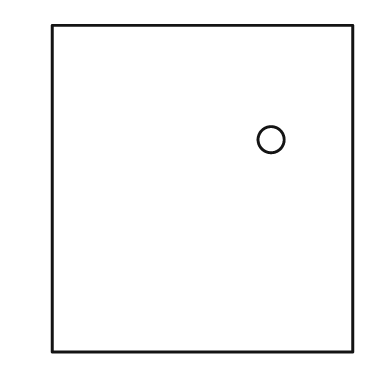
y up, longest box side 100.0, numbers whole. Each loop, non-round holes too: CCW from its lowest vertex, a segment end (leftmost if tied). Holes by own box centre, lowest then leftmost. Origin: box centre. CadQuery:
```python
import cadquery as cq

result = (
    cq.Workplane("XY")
    .moveTo(-46.0, -50.0)
    .lineTo(46.0, -50.0)
    .lineTo(46.0, 50.0)
    .lineTo(-46.0, 50.0)
    .close()
    .moveTo(21.0, 15.0)
    .circle(4.0)
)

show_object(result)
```